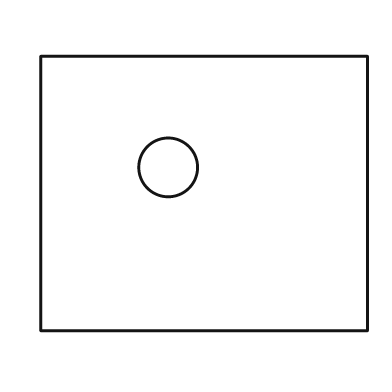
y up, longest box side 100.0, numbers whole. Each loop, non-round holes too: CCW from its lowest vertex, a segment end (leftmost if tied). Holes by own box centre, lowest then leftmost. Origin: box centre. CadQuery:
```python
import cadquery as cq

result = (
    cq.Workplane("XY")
    .moveTo(-50.0, -42.0)
    .lineTo(50.0, -42.0)
    .lineTo(50.0, 42.0)
    .lineTo(-50.0, 42.0)
    .close()
    .moveTo(-11.0, 8.0)
    .circle(9.0)
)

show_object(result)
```